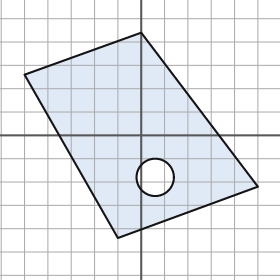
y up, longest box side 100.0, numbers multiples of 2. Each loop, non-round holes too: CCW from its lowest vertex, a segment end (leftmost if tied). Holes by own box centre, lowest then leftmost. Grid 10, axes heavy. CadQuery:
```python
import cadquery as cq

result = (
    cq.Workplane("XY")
    .moveTo(-10.0, -44.0)
    .lineTo(50.0, -22.0)
    .lineTo(0.0, 44.0)
    .lineTo(-50.0, 26.0)
    .close()
    .moveTo(6.0, -18.0)
    .circle(8.0)
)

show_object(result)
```